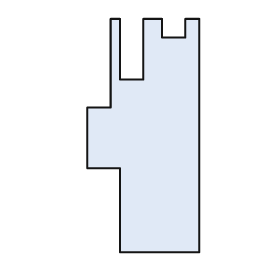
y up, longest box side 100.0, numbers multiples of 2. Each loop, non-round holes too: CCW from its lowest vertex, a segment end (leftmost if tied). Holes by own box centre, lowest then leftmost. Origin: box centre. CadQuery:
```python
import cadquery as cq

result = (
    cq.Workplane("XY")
    .moveTo(-10.0, -50.0)
    .lineTo(24.0, -50.0)
    .lineTo(24.0, 50.0)
    .lineTo(18.0, 50.0)
    .lineTo(18.0, 42.0)
    .lineTo(8.0, 42.0)
    .lineTo(8.0, 50.0)
    .lineTo(0.0, 50.0)
    .lineTo(0.0, 24.0)
    .lineTo(-10.0, 24.0)
    .lineTo(-10.0, 50.0)
    .lineTo(-14.0, 50.0)
    .lineTo(-14.0, 12.0)
    .lineTo(-24.0, 12.0)
    .lineTo(-24.0, -14.0)
    .lineTo(-10.0, -14.0)
    .close()
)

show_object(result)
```